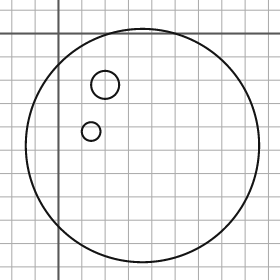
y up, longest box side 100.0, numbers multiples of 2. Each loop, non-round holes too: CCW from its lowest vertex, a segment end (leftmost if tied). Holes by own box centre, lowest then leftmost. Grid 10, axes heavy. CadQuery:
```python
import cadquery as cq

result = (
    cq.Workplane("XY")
    .moveTo(36.0, -48.0)
    .circle(50.0)
    .moveTo(14.0, -42.0)
    .circle(4.0)
    .moveTo(20.0, -22.0)
    .circle(6.0)
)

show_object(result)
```